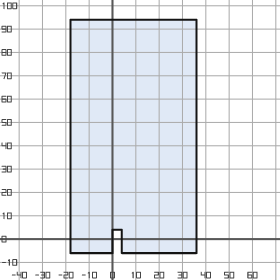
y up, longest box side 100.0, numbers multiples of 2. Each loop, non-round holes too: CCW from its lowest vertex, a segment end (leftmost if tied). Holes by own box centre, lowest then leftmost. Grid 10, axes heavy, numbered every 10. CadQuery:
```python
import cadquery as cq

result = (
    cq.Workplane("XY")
    .moveTo(-18.0, -6.0)
    .lineTo(0.0, -6.0)
    .lineTo(0.0, 4.0)
    .lineTo(4.0, 4.0)
    .lineTo(4.0, -6.0)
    .lineTo(36.0, -6.0)
    .lineTo(36.0, 94.0)
    .lineTo(-18.0, 94.0)
    .close()
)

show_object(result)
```